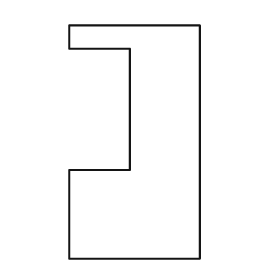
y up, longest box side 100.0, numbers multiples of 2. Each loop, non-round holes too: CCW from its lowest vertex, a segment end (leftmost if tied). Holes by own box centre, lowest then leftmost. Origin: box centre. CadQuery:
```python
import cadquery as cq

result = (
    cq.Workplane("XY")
    .moveTo(-28.0, -50.0)
    .lineTo(28.0, -50.0)
    .lineTo(28.0, 50.0)
    .lineTo(-28.0, 50.0)
    .lineTo(-28.0, 40.0)
    .lineTo(-2.0, 40.0)
    .lineTo(-2.0, -12.0)
    .lineTo(-28.0, -12.0)
    .close()
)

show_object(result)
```